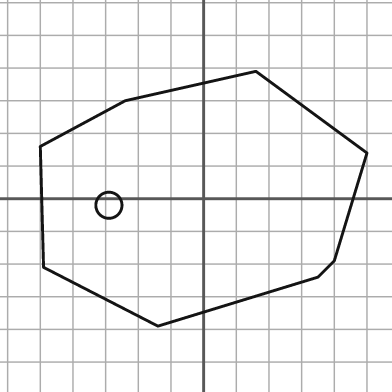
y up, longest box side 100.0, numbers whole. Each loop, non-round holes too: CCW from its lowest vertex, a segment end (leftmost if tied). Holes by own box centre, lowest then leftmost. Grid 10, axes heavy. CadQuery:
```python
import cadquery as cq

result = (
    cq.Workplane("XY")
    .moveTo(-14.0, -39.0)
    .lineTo(35.0, -24.0)
    .lineTo(40.0, -19.0)
    .lineTo(50.0, 14.0)
    .lineTo(16.0, 39.0)
    .lineTo(-24.0, 30.0)
    .lineTo(-50.0, 16.0)
    .lineTo(-49.0, -21.0)
    .close()
    .moveTo(-29.0, -2.0)
    .circle(4.0)
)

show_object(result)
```